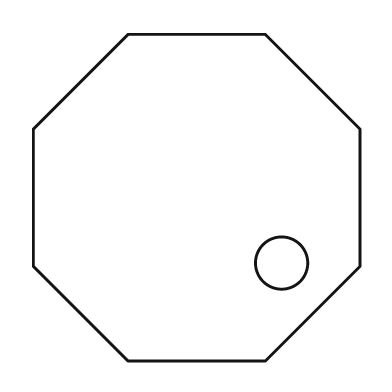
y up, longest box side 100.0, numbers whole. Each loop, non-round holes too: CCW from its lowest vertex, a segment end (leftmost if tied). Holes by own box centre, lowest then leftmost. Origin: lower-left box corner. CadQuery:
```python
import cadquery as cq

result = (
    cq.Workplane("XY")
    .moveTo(29.0, 0.0)
    .lineTo(71.0, 0.0)
    .lineTo(100.0, 29.0)
    .lineTo(100.0, 71.0)
    .lineTo(71.0, 100.0)
    .lineTo(29.0, 100.0)
    .lineTo(0.0, 71.0)
    .lineTo(0.0, 29.0)
    .close()
    .moveTo(76.0, 30.0)
    .circle(8.0)
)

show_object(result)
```